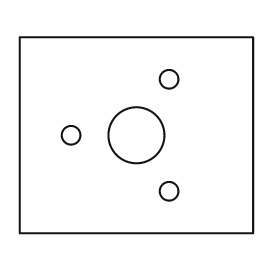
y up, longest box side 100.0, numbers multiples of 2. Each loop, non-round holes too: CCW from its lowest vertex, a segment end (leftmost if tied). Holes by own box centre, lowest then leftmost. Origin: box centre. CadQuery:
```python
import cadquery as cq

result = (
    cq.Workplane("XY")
    .moveTo(-50.0, -42.0)
    .lineTo(50.0, -42.0)
    .lineTo(50.0, 42.0)
    .lineTo(-50.0, 42.0)
    .close()
    .moveTo(14.0, -24.0)
    .circle(4.0)
    .moveTo(-28.0, 0.0)
    .circle(4.0)
    .moveTo(0.0, 0.0)
    .circle(12.0)
    .moveTo(14.0, 24.0)
    .circle(4.0)
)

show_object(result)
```